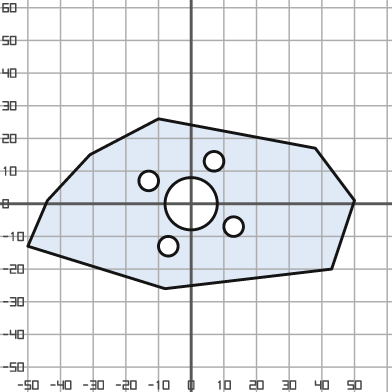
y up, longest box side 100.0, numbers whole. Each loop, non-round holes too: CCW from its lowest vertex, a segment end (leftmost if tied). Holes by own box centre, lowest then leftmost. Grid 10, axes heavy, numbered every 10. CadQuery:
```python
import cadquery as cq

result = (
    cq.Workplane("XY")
    .moveTo(-8.0, -26.0)
    .lineTo(43.0, -20.0)
    .lineTo(50.0, 1.0)
    .lineTo(38.0, 17.0)
    .lineTo(-10.0, 26.0)
    .lineTo(-31.0, 15.0)
    .lineTo(-44.0, 1.0)
    .lineTo(-50.0, -13.0)
    .close()
    .moveTo(-7.0, -13.0)
    .circle(3.0)
    .moveTo(13.0, -7.0)
    .circle(3.0)
    .moveTo(0.0, 0.0)
    .circle(8.0)
    .moveTo(-13.0, 7.0)
    .circle(3.0)
    .moveTo(7.0, 13.0)
    .circle(3.0)
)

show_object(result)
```